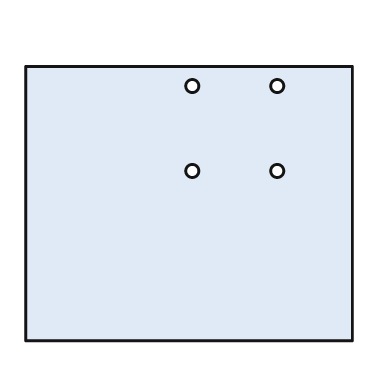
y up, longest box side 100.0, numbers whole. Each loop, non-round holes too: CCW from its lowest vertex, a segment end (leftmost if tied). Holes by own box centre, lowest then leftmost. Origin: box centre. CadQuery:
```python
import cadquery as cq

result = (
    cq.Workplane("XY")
    .moveTo(-50.0, -42.0)
    .lineTo(50.0, -42.0)
    .lineTo(50.0, 42.0)
    .lineTo(-50.0, 42.0)
    .close()
    .moveTo(1.0, 10.0)
    .circle(2.0)
    .moveTo(27.0, 10.0)
    .circle(2.0)
    .moveTo(1.0, 36.0)
    .circle(2.0)
    .moveTo(27.0, 36.0)
    .circle(2.0)
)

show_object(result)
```